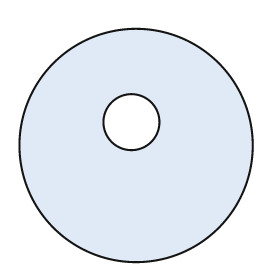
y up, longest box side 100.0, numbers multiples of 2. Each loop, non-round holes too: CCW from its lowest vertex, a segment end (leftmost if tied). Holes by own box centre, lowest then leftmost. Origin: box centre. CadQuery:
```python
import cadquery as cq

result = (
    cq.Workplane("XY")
    .moveTo(0.0, 0.0)
    .circle(50.0)
    .moveTo(-2.0, 10.0)
    .circle(12.0)
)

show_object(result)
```